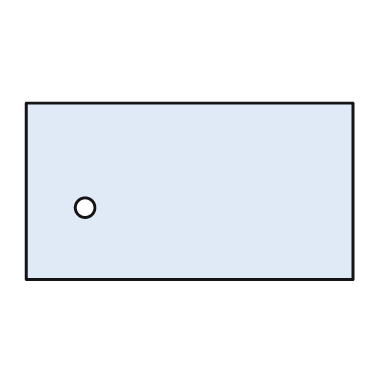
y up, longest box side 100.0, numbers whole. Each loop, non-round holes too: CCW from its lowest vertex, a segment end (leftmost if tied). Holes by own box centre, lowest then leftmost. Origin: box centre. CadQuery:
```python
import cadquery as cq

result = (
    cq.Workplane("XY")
    .moveTo(-50.0, -27.0)
    .lineTo(50.0, -27.0)
    .lineTo(50.0, 27.0)
    .lineTo(-50.0, 27.0)
    .close()
    .moveTo(-32.0, -5.0)
    .circle(3.0)
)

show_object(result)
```